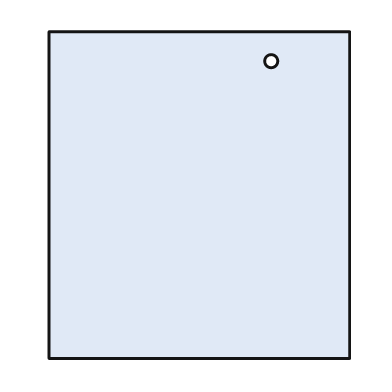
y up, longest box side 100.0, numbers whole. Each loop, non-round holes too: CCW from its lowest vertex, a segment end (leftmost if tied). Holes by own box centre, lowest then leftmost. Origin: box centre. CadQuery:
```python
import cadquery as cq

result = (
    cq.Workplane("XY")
    .moveTo(-46.0, -50.0)
    .lineTo(46.0, -50.0)
    .lineTo(46.0, 50.0)
    .lineTo(-46.0, 50.0)
    .close()
    .moveTo(22.0, 41.0)
    .circle(2.0)
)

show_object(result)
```